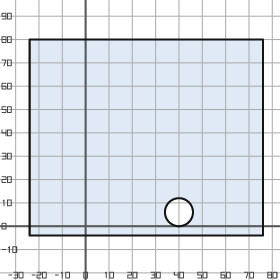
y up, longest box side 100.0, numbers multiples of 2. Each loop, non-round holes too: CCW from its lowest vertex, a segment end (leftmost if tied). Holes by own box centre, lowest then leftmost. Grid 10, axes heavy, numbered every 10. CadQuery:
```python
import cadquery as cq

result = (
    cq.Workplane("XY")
    .moveTo(-24.0, -4.0)
    .lineTo(76.0, -4.0)
    .lineTo(76.0, 80.0)
    .lineTo(-24.0, 80.0)
    .close()
    .moveTo(40.0, 6.0)
    .circle(6.0)
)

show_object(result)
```